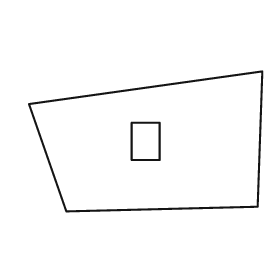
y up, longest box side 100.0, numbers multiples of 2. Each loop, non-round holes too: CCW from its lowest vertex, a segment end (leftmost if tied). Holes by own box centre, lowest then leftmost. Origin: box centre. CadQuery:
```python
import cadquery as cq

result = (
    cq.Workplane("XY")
    .moveTo(-34.0, -30.0)
    .lineTo(48.0, -28.0)
    .lineTo(50.0, 30.0)
    .lineTo(-50.0, 16.0)
    .close()
    .moveTo(-6.0, -8.0)
    .lineTo(6.0, -8.0)
    .lineTo(6.0, 8.0)
    .lineTo(-6.0, 8.0)
    .close()
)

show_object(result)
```